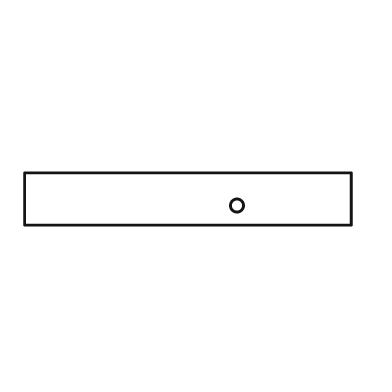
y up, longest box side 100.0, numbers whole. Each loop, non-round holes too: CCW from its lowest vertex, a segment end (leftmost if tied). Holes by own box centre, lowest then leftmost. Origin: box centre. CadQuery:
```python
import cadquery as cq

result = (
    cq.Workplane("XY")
    .moveTo(-50.0, -8.0)
    .lineTo(50.0, -8.0)
    .lineTo(50.0, 8.0)
    .lineTo(-50.0, 8.0)
    .close()
    .moveTo(15.0, -2.0)
    .circle(2.0)
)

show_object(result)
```